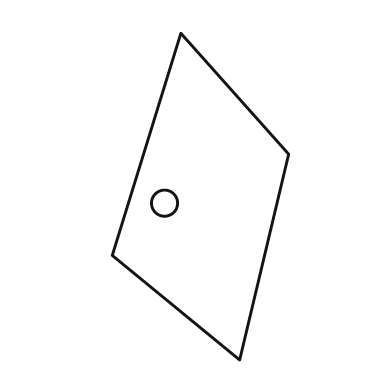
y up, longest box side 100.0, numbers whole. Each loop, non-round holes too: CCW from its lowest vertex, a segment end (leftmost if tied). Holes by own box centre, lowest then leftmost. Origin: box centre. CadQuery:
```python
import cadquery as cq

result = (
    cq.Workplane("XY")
    .moveTo(12.0, -50.0)
    .lineTo(27.0, 13.0)
    .lineTo(-6.0, 50.0)
    .lineTo(-27.0, -18.0)
    .close()
    .moveTo(-11.0, -2.0)
    .circle(4.0)
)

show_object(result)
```